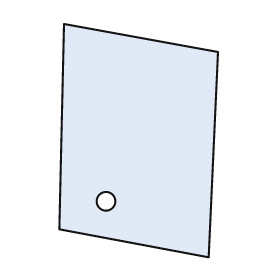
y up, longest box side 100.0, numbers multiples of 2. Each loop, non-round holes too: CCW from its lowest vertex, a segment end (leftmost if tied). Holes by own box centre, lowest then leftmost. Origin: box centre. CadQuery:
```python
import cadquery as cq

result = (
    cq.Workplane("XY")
    .moveTo(30.0, -50.0)
    .lineTo(34.0, 38.0)
    .lineTo(-32.0, 50.0)
    .lineTo(-34.0, -38.0)
    .close()
    .moveTo(-14.0, -26.0)
    .circle(4.0)
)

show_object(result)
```